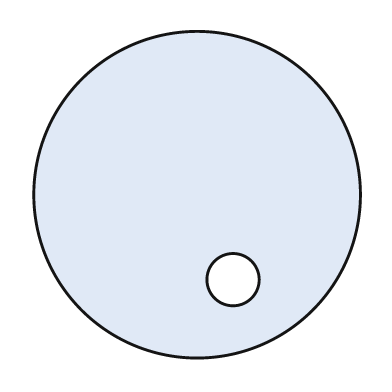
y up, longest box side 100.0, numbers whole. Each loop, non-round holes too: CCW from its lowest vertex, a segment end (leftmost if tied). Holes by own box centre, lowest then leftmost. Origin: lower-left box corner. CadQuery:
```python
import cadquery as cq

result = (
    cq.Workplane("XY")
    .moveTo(50.0, 50.0)
    .circle(50.0)
    .moveTo(61.0, 24.0)
    .circle(8.0)
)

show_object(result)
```